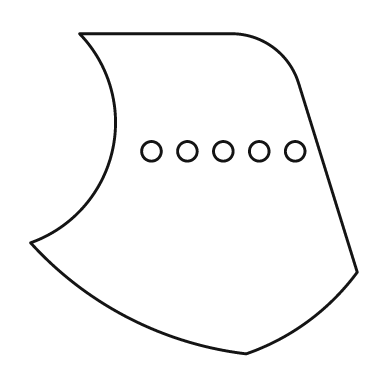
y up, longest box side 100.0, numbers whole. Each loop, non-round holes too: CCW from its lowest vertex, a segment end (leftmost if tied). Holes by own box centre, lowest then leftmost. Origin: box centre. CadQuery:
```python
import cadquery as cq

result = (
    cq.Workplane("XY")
    .moveTo(16.0, -49.0)
    .threePointArc((35.0, -39.0), (50.0, -24.0))
    .lineTo(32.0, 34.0)
    .threePointArc((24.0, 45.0), (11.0, 49.0))
    .lineTo(-35.0, 49.0)
    .threePointArc((-25.0, 13.0), (-50.0, -15.0))
    .threePointArc((-20.0, -38.0), (16.0, -49.0))
    .close()
    .moveTo(-13.0, 13.0)
    .circle(3.0)
    .moveTo(-2.0, 13.0)
    .circle(3.0)
    .moveTo(9.0, 13.0)
    .circle(3.0)
    .moveTo(20.0, 13.0)
    .circle(3.0)
    .moveTo(31.0, 13.0)
    .circle(3.0)
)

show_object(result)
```